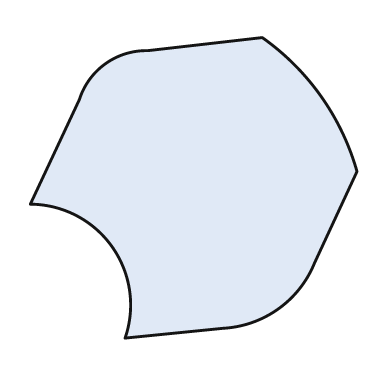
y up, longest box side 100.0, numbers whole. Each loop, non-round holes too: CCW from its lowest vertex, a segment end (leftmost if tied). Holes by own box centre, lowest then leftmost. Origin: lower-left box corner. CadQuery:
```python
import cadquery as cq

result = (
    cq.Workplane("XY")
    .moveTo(29.0, 0.0)
    .lineTo(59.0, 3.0)
    .threePointArc((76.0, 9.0), (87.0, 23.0))
    .lineTo(100.0, 51.0)
    .threePointArc((89.0, 74.0), (71.0, 92.0))
    .lineTo(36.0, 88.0)
    .threePointArc((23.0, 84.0), (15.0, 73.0))
    .lineTo(0.0, 41.0)
    .threePointArc((25.0, 28.0), (29.0, 0.0))
    .close()
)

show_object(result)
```